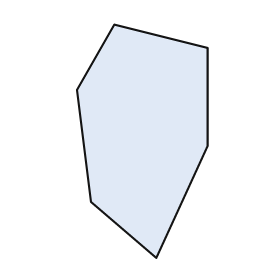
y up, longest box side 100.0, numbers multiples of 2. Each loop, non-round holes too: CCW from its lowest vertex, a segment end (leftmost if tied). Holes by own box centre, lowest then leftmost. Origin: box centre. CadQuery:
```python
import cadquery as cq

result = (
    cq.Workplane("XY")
    .moveTo(6.0, -50.0)
    .lineTo(28.0, -2.0)
    .lineTo(28.0, 40.0)
    .lineTo(-12.0, 50.0)
    .lineTo(-28.0, 22.0)
    .lineTo(-22.0, -26.0)
    .close()
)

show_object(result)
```